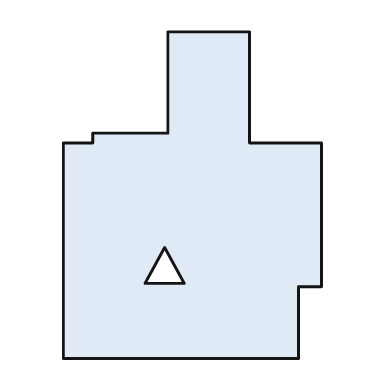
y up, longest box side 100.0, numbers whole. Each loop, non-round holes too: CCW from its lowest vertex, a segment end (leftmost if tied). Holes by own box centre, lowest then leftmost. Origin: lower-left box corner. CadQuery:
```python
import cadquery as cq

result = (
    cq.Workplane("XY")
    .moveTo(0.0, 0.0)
    .lineTo(72.0, 0.0)
    .lineTo(72.0, 22.0)
    .lineTo(79.0, 22.0)
    .lineTo(79.0, 66.0)
    .lineTo(57.0, 66.0)
    .lineTo(57.0, 100.0)
    .lineTo(32.0, 100.0)
    .lineTo(32.0, 69.0)
    .lineTo(9.0, 69.0)
    .lineTo(9.0, 66.0)
    .lineTo(0.0, 66.0)
    .close()
    .moveTo(25.0, 23.0)
    .lineTo(37.0, 23.0)
    .lineTo(31.0, 34.0)
    .close()
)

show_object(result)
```